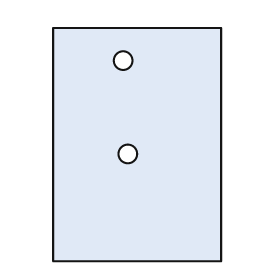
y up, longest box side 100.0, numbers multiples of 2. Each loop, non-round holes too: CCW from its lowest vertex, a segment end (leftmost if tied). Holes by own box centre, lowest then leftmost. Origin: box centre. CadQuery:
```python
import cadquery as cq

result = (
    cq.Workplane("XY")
    .moveTo(-36.0, -50.0)
    .lineTo(36.0, -50.0)
    .lineTo(36.0, 50.0)
    .lineTo(-36.0, 50.0)
    .close()
    .moveTo(-4.0, -4.0)
    .circle(4.0)
    .moveTo(-6.0, 36.0)
    .circle(4.0)
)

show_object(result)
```